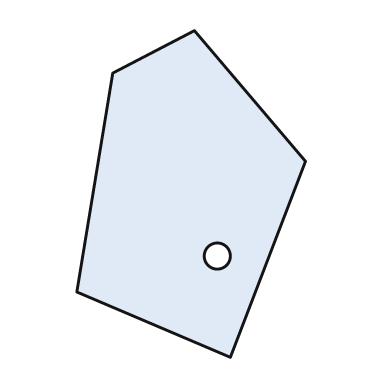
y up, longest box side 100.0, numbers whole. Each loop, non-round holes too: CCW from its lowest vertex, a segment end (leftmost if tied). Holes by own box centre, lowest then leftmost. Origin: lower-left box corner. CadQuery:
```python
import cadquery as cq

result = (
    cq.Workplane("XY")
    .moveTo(47.0, 0.0)
    .lineTo(70.0, 60.0)
    .lineTo(36.0, 100.0)
    .lineTo(11.0, 87.0)
    .lineTo(0.0, 20.0)
    .close()
    .moveTo(43.0, 31.0)
    .circle(4.0)
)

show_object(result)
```